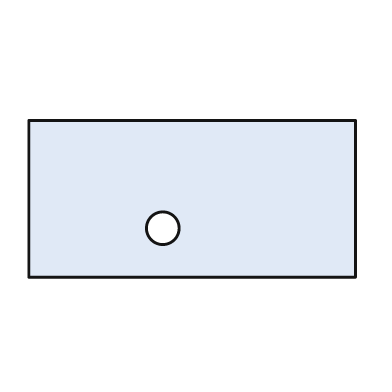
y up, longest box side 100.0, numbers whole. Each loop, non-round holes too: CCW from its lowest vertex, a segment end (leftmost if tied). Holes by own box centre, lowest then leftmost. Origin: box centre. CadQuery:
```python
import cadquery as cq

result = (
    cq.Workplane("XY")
    .moveTo(-50.0, -24.0)
    .lineTo(50.0, -24.0)
    .lineTo(50.0, 24.0)
    .lineTo(-50.0, 24.0)
    .close()
    .moveTo(-9.0, -9.0)
    .circle(5.0)
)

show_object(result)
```